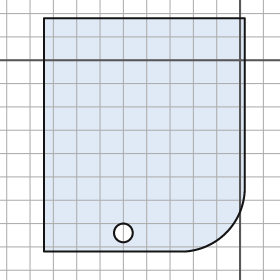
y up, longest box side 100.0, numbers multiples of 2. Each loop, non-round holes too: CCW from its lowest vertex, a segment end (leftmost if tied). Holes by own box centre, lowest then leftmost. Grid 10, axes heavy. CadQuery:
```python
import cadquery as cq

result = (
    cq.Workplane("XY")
    .moveTo(-84.0, -82.0)
    .lineTo(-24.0, -82.0)
    .threePointArc((-6.0, -74.0), (2.0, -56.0))
    .lineTo(2.0, 18.0)
    .lineTo(-84.0, 18.0)
    .close()
    .moveTo(-50.0, -74.0)
    .circle(4.0)
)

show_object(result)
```